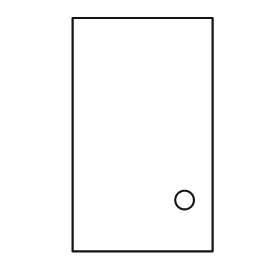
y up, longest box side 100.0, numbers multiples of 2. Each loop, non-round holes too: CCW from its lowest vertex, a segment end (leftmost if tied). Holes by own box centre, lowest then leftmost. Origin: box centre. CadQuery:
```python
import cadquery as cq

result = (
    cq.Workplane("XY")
    .moveTo(-30.0, -50.0)
    .lineTo(30.0, -50.0)
    .lineTo(30.0, 50.0)
    .lineTo(-30.0, 50.0)
    .close()
    .moveTo(18.0, -28.0)
    .circle(4.0)
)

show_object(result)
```